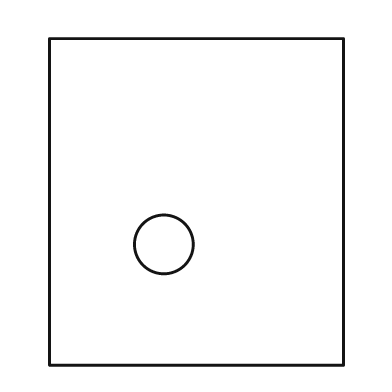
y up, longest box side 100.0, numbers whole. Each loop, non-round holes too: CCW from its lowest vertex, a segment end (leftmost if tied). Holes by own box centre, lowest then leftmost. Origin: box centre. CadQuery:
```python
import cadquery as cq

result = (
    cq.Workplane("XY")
    .moveTo(-45.0, -50.0)
    .lineTo(45.0, -50.0)
    .lineTo(45.0, 50.0)
    .lineTo(-45.0, 50.0)
    .close()
    .moveTo(-10.0, -13.0)
    .circle(9.0)
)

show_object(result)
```